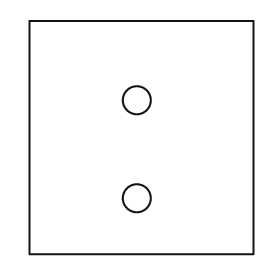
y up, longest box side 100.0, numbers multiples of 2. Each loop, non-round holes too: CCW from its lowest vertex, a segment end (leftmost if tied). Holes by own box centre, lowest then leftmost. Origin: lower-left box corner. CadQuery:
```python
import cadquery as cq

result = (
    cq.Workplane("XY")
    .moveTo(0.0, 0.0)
    .lineTo(96.0, 0.0)
    .lineTo(96.0, 100.0)
    .lineTo(0.0, 100.0)
    .close()
    .moveTo(46.0, 24.0)
    .circle(6.0)
    .moveTo(46.0, 66.0)
    .circle(6.0)
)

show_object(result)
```